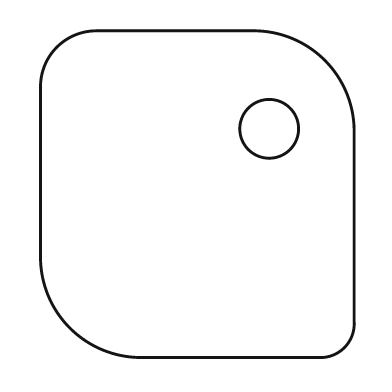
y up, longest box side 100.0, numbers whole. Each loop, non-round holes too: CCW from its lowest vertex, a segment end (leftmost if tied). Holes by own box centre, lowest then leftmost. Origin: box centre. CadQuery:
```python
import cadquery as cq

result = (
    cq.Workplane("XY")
    .moveTo(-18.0, -50.0)
    .lineTo(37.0, -50.0)
    .threePointArc((45.0, -47.0), (48.0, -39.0))
    .lineTo(48.0, 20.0)
    .threePointArc((39.0, 41.0), (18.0, 50.0))
    .lineTo(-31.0, 50.0)
    .threePointArc((-43.0, 45.0), (-48.0, 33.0))
    .lineTo(-48.0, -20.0)
    .threePointArc((-39.0, -41.0), (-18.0, -50.0))
    .close()
    .moveTo(22.0, 20.0)
    .circle(9.0)
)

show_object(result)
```